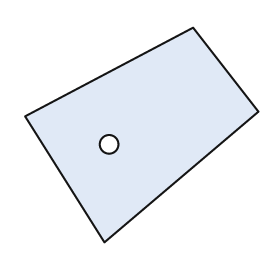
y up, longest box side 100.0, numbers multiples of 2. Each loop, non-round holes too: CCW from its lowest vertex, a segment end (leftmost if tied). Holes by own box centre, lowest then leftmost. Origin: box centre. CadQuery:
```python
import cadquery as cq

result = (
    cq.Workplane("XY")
    .moveTo(-16.0, -46.0)
    .lineTo(50.0, 10.0)
    .lineTo(22.0, 46.0)
    .lineTo(-50.0, 8.0)
    .close()
    .moveTo(-14.0, -4.0)
    .circle(4.0)
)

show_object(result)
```